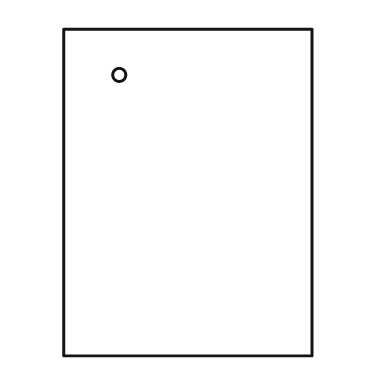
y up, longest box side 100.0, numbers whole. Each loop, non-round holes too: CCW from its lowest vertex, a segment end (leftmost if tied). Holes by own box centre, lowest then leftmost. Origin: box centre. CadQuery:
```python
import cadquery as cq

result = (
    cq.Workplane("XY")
    .moveTo(-38.0, -50.0)
    .lineTo(38.0, -50.0)
    .lineTo(38.0, 50.0)
    .lineTo(-38.0, 50.0)
    .close()
    .moveTo(-21.0, 36.0)
    .circle(2.0)
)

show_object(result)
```